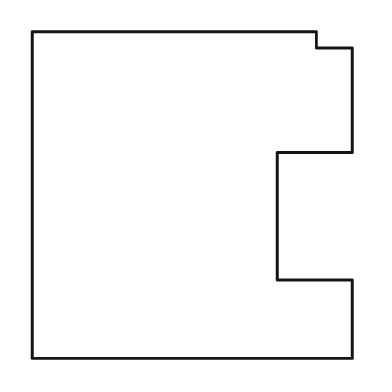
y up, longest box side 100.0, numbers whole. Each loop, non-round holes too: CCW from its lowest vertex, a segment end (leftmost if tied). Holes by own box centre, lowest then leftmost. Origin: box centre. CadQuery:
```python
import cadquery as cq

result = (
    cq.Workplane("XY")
    .moveTo(-49.0, -50.0)
    .lineTo(49.0, -50.0)
    .lineTo(49.0, -26.0)
    .lineTo(26.0, -26.0)
    .lineTo(26.0, 13.0)
    .lineTo(49.0, 13.0)
    .lineTo(49.0, 45.0)
    .lineTo(38.0, 45.0)
    .lineTo(38.0, 50.0)
    .lineTo(-49.0, 50.0)
    .close()
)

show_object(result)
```